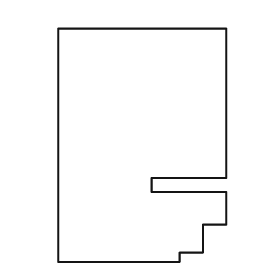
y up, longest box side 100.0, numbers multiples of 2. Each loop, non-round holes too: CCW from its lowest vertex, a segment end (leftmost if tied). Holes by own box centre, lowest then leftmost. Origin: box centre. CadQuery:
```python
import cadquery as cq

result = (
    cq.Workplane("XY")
    .moveTo(-36.0, -50.0)
    .lineTo(16.0, -50.0)
    .lineTo(16.0, -46.0)
    .lineTo(26.0, -46.0)
    .lineTo(26.0, -34.0)
    .lineTo(36.0, -34.0)
    .lineTo(36.0, -20.0)
    .lineTo(4.0, -20.0)
    .lineTo(4.0, -14.0)
    .lineTo(36.0, -14.0)
    .lineTo(36.0, 50.0)
    .lineTo(-36.0, 50.0)
    .close()
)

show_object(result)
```